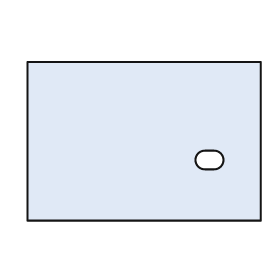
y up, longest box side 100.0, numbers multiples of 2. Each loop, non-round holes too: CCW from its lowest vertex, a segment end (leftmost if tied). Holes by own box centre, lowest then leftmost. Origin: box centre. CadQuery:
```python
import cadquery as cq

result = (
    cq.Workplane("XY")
    .moveTo(-50.0, -34.0)
    .lineTo(50.0, -34.0)
    .lineTo(50.0, 34.0)
    .lineTo(-50.0, 34.0)
    .close()
    .moveTo(26.0, -12.0)
    .lineTo(30.0, -12.0)
    .threePointArc((34.0, -8.0), (30.0, -4.0))
    .lineTo(26.0, -4.0)
    .threePointArc((22.0, -8.0), (26.0, -12.0))
    .close()
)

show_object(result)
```